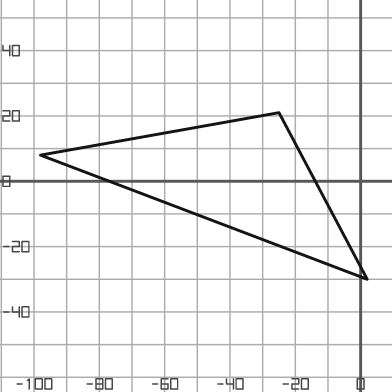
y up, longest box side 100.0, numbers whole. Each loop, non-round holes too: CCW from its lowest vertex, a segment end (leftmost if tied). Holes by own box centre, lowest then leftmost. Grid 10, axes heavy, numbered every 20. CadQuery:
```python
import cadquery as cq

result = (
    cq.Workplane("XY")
    .moveTo(2.0, -30.0)
    .lineTo(-25.0, 21.0)
    .lineTo(-98.0, 8.0)
    .close()
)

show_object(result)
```